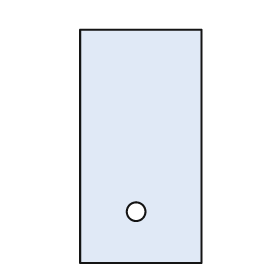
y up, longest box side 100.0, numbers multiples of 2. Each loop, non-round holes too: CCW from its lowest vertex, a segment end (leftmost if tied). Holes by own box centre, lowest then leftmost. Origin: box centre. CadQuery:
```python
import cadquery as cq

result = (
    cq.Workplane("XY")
    .moveTo(-26.0, -50.0)
    .lineTo(26.0, -50.0)
    .lineTo(26.0, 50.0)
    .lineTo(-26.0, 50.0)
    .close()
    .moveTo(-2.0, -28.0)
    .circle(4.0)
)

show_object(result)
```